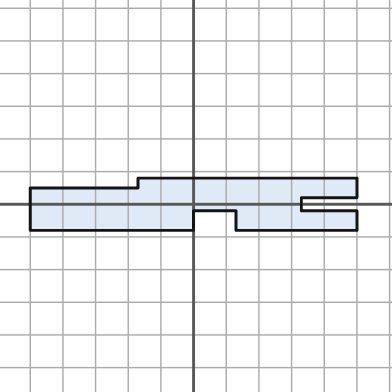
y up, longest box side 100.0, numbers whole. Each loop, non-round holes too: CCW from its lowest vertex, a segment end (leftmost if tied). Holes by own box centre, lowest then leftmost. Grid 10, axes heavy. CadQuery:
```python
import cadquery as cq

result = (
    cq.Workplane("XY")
    .moveTo(-50.0, -8.0)
    .lineTo(0.0, -8.0)
    .lineTo(0.0, -2.0)
    .lineTo(13.0, -2.0)
    .lineTo(13.0, -8.0)
    .lineTo(50.0, -8.0)
    .lineTo(50.0, -2.0)
    .lineTo(33.0, -2.0)
    .lineTo(33.0, 2.0)
    .lineTo(50.0, 2.0)
    .lineTo(50.0, 8.0)
    .lineTo(-17.0, 8.0)
    .lineTo(-17.0, 5.0)
    .lineTo(-50.0, 5.0)
    .close()
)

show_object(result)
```